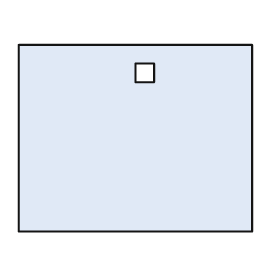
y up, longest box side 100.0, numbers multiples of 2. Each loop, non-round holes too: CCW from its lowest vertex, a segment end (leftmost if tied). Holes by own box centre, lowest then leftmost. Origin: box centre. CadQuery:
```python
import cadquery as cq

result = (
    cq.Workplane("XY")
    .moveTo(-50.0, -40.0)
    .lineTo(50.0, -40.0)
    .lineTo(50.0, 40.0)
    .lineTo(-50.0, 40.0)
    .close()
    .moveTo(0.0, 24.0)
    .lineTo(8.0, 24.0)
    .lineTo(8.0, 32.0)
    .lineTo(0.0, 32.0)
    .close()
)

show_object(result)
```